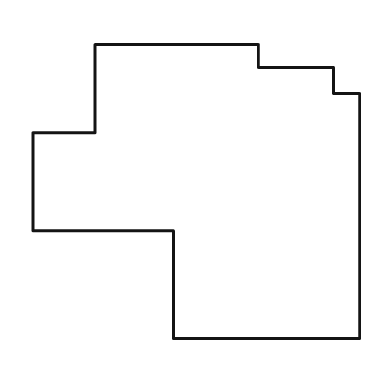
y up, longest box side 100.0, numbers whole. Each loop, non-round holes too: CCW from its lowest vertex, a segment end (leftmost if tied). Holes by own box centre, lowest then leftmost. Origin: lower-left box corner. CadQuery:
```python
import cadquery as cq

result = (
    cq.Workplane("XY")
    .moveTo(43.0, 0.0)
    .lineTo(100.0, 0.0)
    .lineTo(100.0, 75.0)
    .lineTo(92.0, 75.0)
    .lineTo(92.0, 83.0)
    .lineTo(69.0, 83.0)
    .lineTo(69.0, 90.0)
    .lineTo(19.0, 90.0)
    .lineTo(19.0, 63.0)
    .lineTo(0.0, 63.0)
    .lineTo(0.0, 33.0)
    .lineTo(43.0, 33.0)
    .close()
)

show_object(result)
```